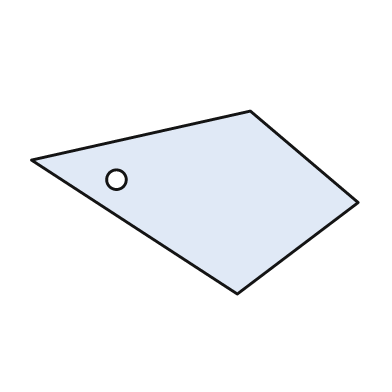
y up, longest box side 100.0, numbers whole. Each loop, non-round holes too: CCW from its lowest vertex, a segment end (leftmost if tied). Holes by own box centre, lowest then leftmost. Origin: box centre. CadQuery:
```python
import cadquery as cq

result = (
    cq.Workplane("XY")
    .moveTo(13.0, -28.0)
    .lineTo(50.0, 0.0)
    .lineTo(17.0, 28.0)
    .lineTo(-50.0, 13.0)
    .close()
    .moveTo(-24.0, 7.0)
    .circle(3.0)
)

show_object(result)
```